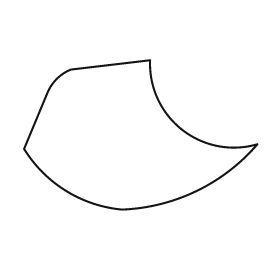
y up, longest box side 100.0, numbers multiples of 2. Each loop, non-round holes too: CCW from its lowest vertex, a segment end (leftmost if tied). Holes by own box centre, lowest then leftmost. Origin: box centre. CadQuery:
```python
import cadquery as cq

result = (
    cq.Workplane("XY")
    .moveTo(-8.0, -32.0)
    .threePointArc((24.0, -24.0), (50.0, -4.0))
    .threePointArc((18.0, 2.0), (4.0, 32.0))
    .lineTo(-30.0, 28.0)
    .threePointArc((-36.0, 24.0), (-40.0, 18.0))
    .lineTo(-50.0, -6.0)
    .threePointArc((-32.0, -24.0), (-8.0, -32.0))
    .close()
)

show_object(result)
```